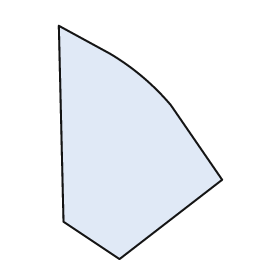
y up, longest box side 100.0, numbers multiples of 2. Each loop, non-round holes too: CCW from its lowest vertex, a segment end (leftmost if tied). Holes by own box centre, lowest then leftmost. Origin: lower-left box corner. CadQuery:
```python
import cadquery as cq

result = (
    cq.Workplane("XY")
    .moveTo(26.0, 0.0)
    .lineTo(70.0, 34.0)
    .lineTo(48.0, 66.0)
    .threePointArc((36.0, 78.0), (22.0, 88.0))
    .lineTo(0.0, 100.0)
    .lineTo(2.0, 16.0)
    .close()
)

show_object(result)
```